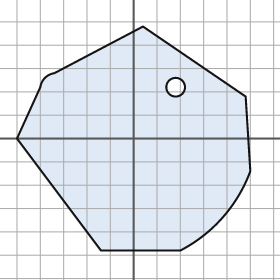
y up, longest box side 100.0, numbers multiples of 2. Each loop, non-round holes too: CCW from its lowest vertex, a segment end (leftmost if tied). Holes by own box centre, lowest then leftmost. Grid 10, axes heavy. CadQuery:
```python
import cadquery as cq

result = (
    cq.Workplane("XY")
    .moveTo(-14.0, -48.0)
    .lineTo(20.0, -48.0)
    .threePointArc((38.0, -34.0), (50.0, -14.0))
    .lineTo(48.0, 18.0)
    .lineTo(4.0, 48.0)
    .lineTo(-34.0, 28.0)
    .threePointArc((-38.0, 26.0), (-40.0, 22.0))
    .lineTo(-50.0, 0.0)
    .close()
    .moveTo(18.0, 22.0)
    .circle(4.0)
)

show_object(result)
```